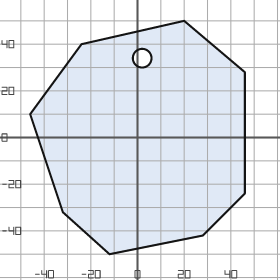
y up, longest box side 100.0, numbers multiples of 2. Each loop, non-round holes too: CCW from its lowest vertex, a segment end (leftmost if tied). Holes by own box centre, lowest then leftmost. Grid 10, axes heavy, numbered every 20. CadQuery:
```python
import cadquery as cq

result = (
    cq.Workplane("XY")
    .moveTo(-12.0, -50.0)
    .lineTo(28.0, -42.0)
    .lineTo(46.0, -24.0)
    .lineTo(46.0, 28.0)
    .lineTo(20.0, 50.0)
    .lineTo(-24.0, 40.0)
    .lineTo(-46.0, 10.0)
    .lineTo(-32.0, -32.0)
    .close()
    .moveTo(2.0, 34.0)
    .circle(4.0)
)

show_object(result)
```